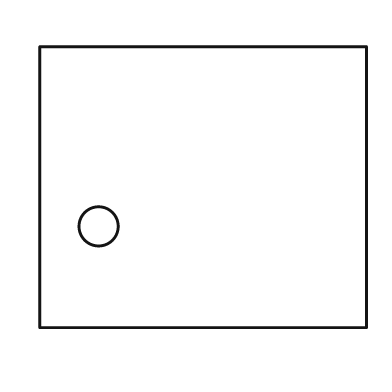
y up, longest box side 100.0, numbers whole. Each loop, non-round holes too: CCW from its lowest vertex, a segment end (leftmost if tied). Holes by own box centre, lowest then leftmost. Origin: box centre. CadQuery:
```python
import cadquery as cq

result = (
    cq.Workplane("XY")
    .moveTo(-50.0, -43.0)
    .lineTo(50.0, -43.0)
    .lineTo(50.0, 43.0)
    .lineTo(-50.0, 43.0)
    .close()
    .moveTo(-32.0, -12.0)
    .circle(6.0)
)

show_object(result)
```